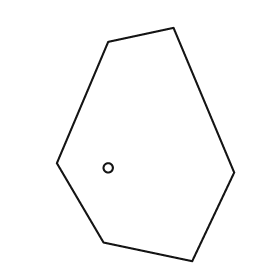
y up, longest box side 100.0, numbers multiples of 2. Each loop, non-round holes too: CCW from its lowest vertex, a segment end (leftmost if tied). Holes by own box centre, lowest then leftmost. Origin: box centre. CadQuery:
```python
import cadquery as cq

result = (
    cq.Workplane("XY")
    .moveTo(20.0, -50.0)
    .lineTo(38.0, -12.0)
    .lineTo(12.0, 50.0)
    .lineTo(-16.0, 44.0)
    .lineTo(-38.0, -8.0)
    .lineTo(-18.0, -42.0)
    .close()
    .moveTo(-16.0, -10.0)
    .circle(2.0)
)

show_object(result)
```